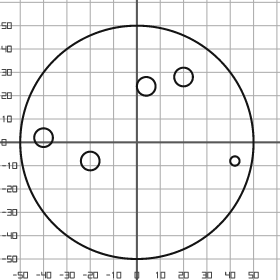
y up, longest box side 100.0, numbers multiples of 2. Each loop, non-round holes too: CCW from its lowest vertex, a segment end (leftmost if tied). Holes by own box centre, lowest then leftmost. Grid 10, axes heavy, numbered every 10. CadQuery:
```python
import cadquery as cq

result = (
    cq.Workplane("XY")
    .moveTo(0.0, 0.0)
    .circle(50.0)
    .moveTo(-20.0, -8.0)
    .circle(4.0)
    .moveTo(42.0, -8.0)
    .circle(2.0)
    .moveTo(-40.0, 2.0)
    .circle(4.0)
    .moveTo(4.0, 24.0)
    .circle(4.0)
    .moveTo(20.0, 28.0)
    .circle(4.0)
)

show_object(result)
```